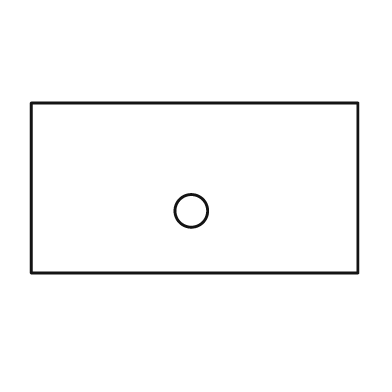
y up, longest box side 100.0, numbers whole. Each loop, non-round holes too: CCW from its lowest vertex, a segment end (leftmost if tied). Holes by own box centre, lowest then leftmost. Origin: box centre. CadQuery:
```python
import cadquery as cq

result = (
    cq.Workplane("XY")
    .moveTo(-50.0, -26.0)
    .lineTo(50.0, -26.0)
    .lineTo(50.0, 26.0)
    .lineTo(-50.0, 26.0)
    .close()
    .moveTo(-1.0, -7.0)
    .circle(5.0)
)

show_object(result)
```